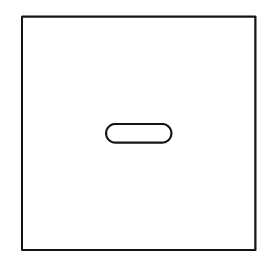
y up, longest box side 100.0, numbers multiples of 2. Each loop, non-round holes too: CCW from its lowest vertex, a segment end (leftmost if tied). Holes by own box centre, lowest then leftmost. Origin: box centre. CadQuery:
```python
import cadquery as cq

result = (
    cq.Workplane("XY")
    .moveTo(-50.0, -50.0)
    .lineTo(50.0, -50.0)
    .lineTo(50.0, 50.0)
    .lineTo(-50.0, 50.0)
    .close()
    .moveTo(-10.0, -4.0)
    .lineTo(10.0, -4.0)
    .threePointArc((14.0, 0.0), (10.0, 4.0))
    .lineTo(-10.0, 4.0)
    .threePointArc((-14.0, 0.0), (-10.0, -4.0))
    .close()
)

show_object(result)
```